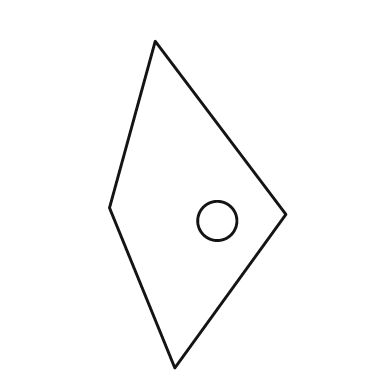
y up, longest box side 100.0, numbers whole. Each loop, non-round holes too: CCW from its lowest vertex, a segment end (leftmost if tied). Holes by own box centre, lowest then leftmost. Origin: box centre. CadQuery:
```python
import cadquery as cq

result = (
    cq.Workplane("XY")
    .moveTo(-7.0, -50.0)
    .lineTo(27.0, -3.0)
    .lineTo(-13.0, 50.0)
    .lineTo(-27.0, -1.0)
    .close()
    .moveTo(6.0, -5.0)
    .circle(6.0)
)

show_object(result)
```